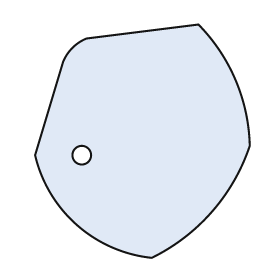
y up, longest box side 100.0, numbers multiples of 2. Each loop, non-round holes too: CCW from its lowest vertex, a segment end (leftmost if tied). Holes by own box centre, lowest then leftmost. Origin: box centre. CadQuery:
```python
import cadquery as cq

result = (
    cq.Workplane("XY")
    .moveTo(4.0, -50.0)
    .threePointArc((30.0, -30.0), (46.0, -2.0))
    .threePointArc((40.0, 26.0), (24.0, 50.0))
    .lineTo(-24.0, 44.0)
    .threePointArc((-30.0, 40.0), (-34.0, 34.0))
    .lineTo(-46.0, -6.0)
    .threePointArc((-28.0, -36.0), (4.0, -50.0))
    .close()
    .moveTo(-26.0, -6.0)
    .circle(4.0)
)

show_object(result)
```